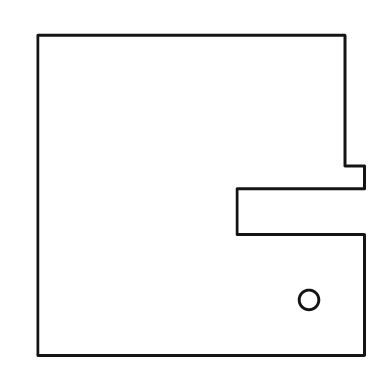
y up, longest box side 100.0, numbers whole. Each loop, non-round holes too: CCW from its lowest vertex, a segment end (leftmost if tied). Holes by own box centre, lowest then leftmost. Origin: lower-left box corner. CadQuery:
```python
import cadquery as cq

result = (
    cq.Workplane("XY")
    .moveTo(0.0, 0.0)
    .lineTo(100.0, 0.0)
    .lineTo(100.0, 37.0)
    .lineTo(61.0, 37.0)
    .lineTo(61.0, 51.0)
    .lineTo(100.0, 51.0)
    .lineTo(100.0, 58.0)
    .lineTo(94.0, 58.0)
    .lineTo(94.0, 98.0)
    .lineTo(0.0, 98.0)
    .close()
    .moveTo(83.0, 17.0)
    .circle(3.0)
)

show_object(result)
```